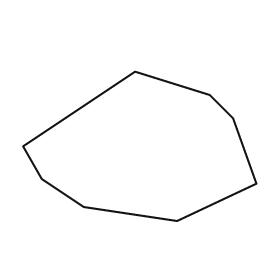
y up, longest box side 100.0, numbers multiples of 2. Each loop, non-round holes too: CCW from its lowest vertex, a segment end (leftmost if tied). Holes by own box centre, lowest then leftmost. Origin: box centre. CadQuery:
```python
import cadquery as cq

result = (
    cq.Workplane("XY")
    .moveTo(16.0, -32.0)
    .lineTo(50.0, -16.0)
    .lineTo(40.0, 12.0)
    .lineTo(30.0, 22.0)
    .lineTo(-2.0, 32.0)
    .lineTo(-50.0, 0.0)
    .lineTo(-42.0, -14.0)
    .lineTo(-24.0, -26.0)
    .close()
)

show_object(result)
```